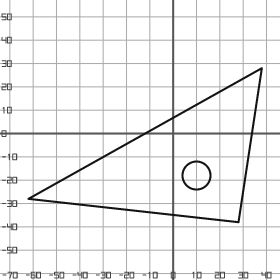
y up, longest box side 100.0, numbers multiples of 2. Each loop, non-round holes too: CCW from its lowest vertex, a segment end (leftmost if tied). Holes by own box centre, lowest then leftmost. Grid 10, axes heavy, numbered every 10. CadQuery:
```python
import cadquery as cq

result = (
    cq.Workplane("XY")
    .moveTo(28.0, -38.0)
    .lineTo(38.0, 28.0)
    .lineTo(-62.0, -28.0)
    .close()
    .moveTo(10.0, -18.0)
    .circle(6.0)
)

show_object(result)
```